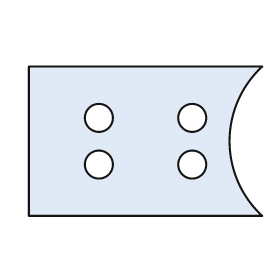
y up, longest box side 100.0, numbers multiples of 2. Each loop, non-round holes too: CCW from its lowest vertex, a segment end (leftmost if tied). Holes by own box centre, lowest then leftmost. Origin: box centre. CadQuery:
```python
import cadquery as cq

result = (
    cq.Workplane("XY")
    .moveTo(-50.0, -32.0)
    .lineTo(50.0, -32.0)
    .threePointArc((36.0, 0.0), (50.0, 32.0))
    .lineTo(-50.0, 32.0)
    .close()
    .moveTo(-20.0, -10.0)
    .circle(6.0)
    .moveTo(20.0, -10.0)
    .circle(6.0)
    .moveTo(-20.0, 10.0)
    .circle(6.0)
    .moveTo(20.0, 10.0)
    .circle(6.0)
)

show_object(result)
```